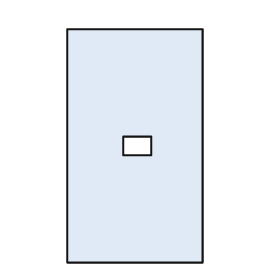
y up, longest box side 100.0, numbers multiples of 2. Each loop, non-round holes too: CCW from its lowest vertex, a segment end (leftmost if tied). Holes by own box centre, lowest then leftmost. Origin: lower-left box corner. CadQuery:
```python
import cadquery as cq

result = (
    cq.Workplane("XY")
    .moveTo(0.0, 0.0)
    .lineTo(58.0, 0.0)
    .lineTo(58.0, 100.0)
    .lineTo(0.0, 100.0)
    .close()
    .moveTo(24.0, 46.0)
    .lineTo(36.0, 46.0)
    .lineTo(36.0, 54.0)
    .lineTo(24.0, 54.0)
    .close()
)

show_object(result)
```